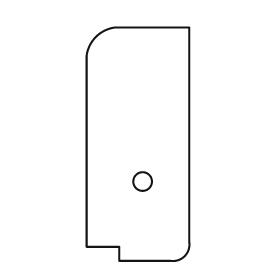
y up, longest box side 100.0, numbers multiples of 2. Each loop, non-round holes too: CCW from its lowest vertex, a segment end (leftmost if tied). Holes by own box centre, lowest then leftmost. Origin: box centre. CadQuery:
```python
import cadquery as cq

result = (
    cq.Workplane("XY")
    .moveTo(-8.0, -50.0)
    .lineTo(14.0, -50.0)
    .threePointArc((20.0, -48.0), (22.0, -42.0))
    .lineTo(22.0, 50.0)
    .lineTo(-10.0, 50.0)
    .threePointArc((-18.0, 46.0), (-22.0, 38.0))
    .lineTo(-22.0, -44.0)
    .lineTo(-8.0, -44.0)
    .close()
    .moveTo(2.0, -16.0)
    .circle(4.0)
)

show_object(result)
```